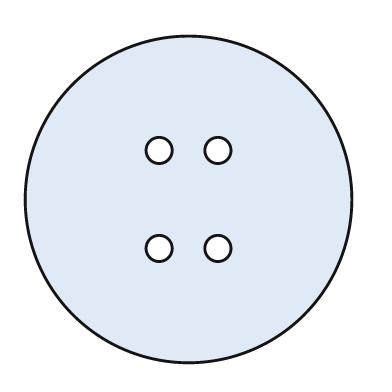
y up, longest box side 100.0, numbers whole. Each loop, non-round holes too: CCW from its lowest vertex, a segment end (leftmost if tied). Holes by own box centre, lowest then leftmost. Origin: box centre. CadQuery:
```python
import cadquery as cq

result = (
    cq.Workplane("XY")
    .moveTo(0.0, 0.0)
    .circle(50.0)
    .moveTo(-9.0, -15.0)
    .circle(4.0)
    .moveTo(9.0, -15.0)
    .circle(4.0)
    .moveTo(-9.0, 15.0)
    .circle(4.0)
    .moveTo(9.0, 15.0)
    .circle(4.0)
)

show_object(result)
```